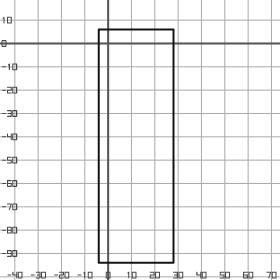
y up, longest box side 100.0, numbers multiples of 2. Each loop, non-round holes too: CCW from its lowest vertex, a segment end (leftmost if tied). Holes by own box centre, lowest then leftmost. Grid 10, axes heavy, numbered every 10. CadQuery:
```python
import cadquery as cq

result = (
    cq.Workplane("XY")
    .moveTo(-4.0, -94.0)
    .lineTo(28.0, -94.0)
    .lineTo(28.0, 6.0)
    .lineTo(-4.0, 6.0)
    .close()
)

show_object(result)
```